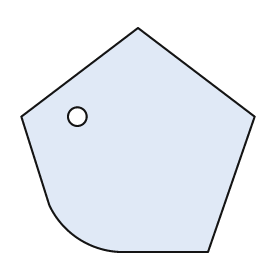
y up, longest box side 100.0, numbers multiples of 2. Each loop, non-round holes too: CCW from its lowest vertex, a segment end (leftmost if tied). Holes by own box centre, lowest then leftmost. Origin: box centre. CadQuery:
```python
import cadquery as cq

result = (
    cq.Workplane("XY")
    .moveTo(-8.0, -48.0)
    .lineTo(30.0, -48.0)
    .lineTo(50.0, 10.0)
    .lineTo(0.0, 48.0)
    .lineTo(-50.0, 10.0)
    .lineTo(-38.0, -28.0)
    .threePointArc((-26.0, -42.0), (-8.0, -48.0))
    .close()
    .moveTo(-26.0, 10.0)
    .circle(4.0)
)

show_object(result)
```